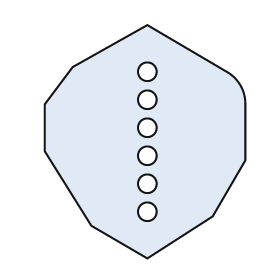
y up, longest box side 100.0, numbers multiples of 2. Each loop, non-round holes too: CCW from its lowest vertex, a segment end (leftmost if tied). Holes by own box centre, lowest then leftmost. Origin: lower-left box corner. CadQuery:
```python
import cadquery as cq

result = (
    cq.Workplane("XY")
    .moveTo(44.0, 0.0)
    .lineTo(72.0, 18.0)
    .lineTo(86.0, 42.0)
    .lineTo(86.0, 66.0)
    .threePointArc((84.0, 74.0), (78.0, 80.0))
    .lineTo(44.0, 100.0)
    .lineTo(12.0, 82.0)
    .lineTo(0.0, 66.0)
    .lineTo(0.0, 46.0)
    .lineTo(20.0, 14.0)
    .close()
    .moveTo(44.0, 20.0)
    .circle(4.0)
    .moveTo(44.0, 32.0)
    .circle(4.0)
    .moveTo(44.0, 44.0)
    .circle(4.0)
    .moveTo(44.0, 56.0)
    .circle(4.0)
    .moveTo(44.0, 68.0)
    .circle(4.0)
    .moveTo(44.0, 80.0)
    .circle(4.0)
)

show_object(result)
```